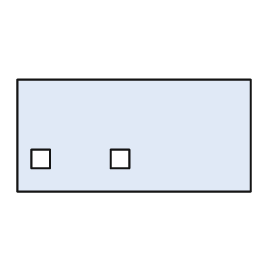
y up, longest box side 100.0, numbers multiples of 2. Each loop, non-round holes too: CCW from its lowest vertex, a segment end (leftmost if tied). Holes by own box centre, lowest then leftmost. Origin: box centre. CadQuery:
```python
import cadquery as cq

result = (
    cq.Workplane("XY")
    .moveTo(-50.0, -24.0)
    .lineTo(50.0, -24.0)
    .lineTo(50.0, 24.0)
    .lineTo(-50.0, 24.0)
    .close()
    .moveTo(-44.0, -14.0)
    .lineTo(-36.0, -14.0)
    .lineTo(-36.0, -6.0)
    .lineTo(-44.0, -6.0)
    .close()
    .moveTo(-10.0, -14.0)
    .lineTo(-2.0, -14.0)
    .lineTo(-2.0, -6.0)
    .lineTo(-10.0, -6.0)
    .close()
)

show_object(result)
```